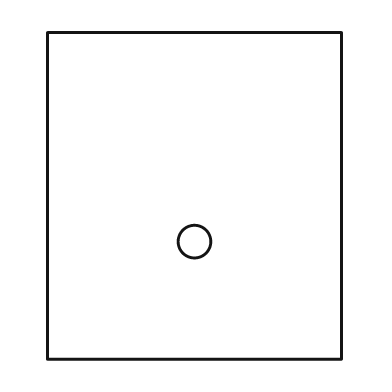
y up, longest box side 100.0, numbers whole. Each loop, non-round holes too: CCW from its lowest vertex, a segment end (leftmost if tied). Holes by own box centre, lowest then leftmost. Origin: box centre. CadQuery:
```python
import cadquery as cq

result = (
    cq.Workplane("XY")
    .moveTo(-45.0, -50.0)
    .lineTo(45.0, -50.0)
    .lineTo(45.0, 50.0)
    .lineTo(-45.0, 50.0)
    .close()
    .moveTo(0.0, -14.0)
    .circle(5.0)
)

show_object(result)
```